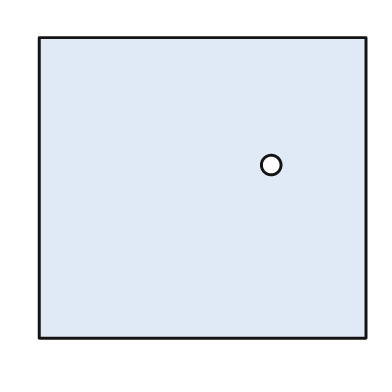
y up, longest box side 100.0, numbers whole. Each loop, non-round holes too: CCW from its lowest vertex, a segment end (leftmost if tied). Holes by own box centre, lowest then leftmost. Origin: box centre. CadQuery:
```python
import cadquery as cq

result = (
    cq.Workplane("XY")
    .moveTo(-50.0, -46.0)
    .lineTo(50.0, -46.0)
    .lineTo(50.0, 46.0)
    .lineTo(-50.0, 46.0)
    .close()
    .moveTo(21.0, 7.0)
    .circle(3.0)
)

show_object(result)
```